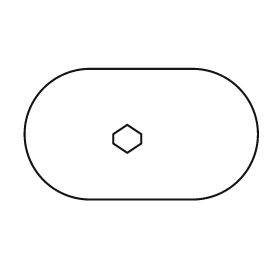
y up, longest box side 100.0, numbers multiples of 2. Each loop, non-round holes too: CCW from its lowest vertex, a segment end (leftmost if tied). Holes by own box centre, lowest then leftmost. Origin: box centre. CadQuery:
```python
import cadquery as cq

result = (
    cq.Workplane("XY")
    .moveTo(-22.0, -28.0)
    .lineTo(22.0, -28.0)
    .threePointArc((50.0, 0.0), (22.0, 28.0))
    .lineTo(-22.0, 28.0)
    .threePointArc((-50.0, 0.0), (-22.0, -28.0))
    .close()
    .moveTo(-6.0, -8.0)
    .lineTo(0.0, -4.0)
    .lineTo(0.0, 0.0)
    .lineTo(-6.0, 4.0)
    .lineTo(-12.0, 0.0)
    .lineTo(-12.0, -4.0)
    .close()
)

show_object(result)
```